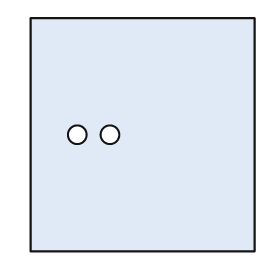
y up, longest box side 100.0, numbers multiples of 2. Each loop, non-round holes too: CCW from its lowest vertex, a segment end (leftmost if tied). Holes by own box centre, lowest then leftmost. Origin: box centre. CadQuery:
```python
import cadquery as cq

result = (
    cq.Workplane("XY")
    .moveTo(-48.0, -50.0)
    .lineTo(48.0, -50.0)
    .lineTo(48.0, 50.0)
    .lineTo(-48.0, 50.0)
    .close()
    .moveTo(-28.0, 0.0)
    .circle(4.0)
    .moveTo(-14.0, 0.0)
    .circle(4.0)
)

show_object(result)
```